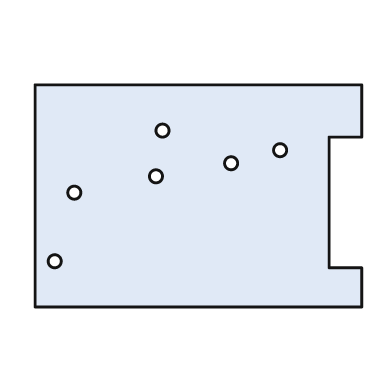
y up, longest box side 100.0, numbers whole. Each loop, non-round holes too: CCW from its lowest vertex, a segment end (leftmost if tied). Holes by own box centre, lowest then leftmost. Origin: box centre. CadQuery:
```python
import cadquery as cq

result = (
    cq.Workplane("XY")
    .moveTo(-50.0, -34.0)
    .lineTo(50.0, -34.0)
    .lineTo(50.0, -22.0)
    .lineTo(40.0, -22.0)
    .lineTo(40.0, 18.0)
    .lineTo(50.0, 18.0)
    .lineTo(50.0, 34.0)
    .lineTo(-50.0, 34.0)
    .close()
    .moveTo(-44.0, -20.0)
    .circle(2.0)
    .moveTo(-38.0, 1.0)
    .circle(2.0)
    .moveTo(-13.0, 6.0)
    .circle(2.0)
    .moveTo(10.0, 10.0)
    .circle(2.0)
    .moveTo(25.0, 14.0)
    .circle(2.0)
    .moveTo(-11.0, 20.0)
    .circle(2.0)
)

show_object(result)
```